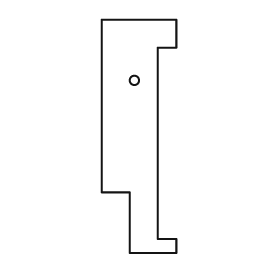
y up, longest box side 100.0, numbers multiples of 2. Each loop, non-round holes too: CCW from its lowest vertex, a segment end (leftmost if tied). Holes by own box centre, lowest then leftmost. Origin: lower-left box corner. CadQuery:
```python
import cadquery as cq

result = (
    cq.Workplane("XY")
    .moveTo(12.0, 0.0)
    .lineTo(32.0, 0.0)
    .lineTo(32.0, 6.0)
    .lineTo(24.0, 6.0)
    .lineTo(24.0, 88.0)
    .lineTo(32.0, 88.0)
    .lineTo(32.0, 100.0)
    .lineTo(0.0, 100.0)
    .lineTo(0.0, 26.0)
    .lineTo(12.0, 26.0)
    .close()
    .moveTo(14.0, 74.0)
    .circle(2.0)
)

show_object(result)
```